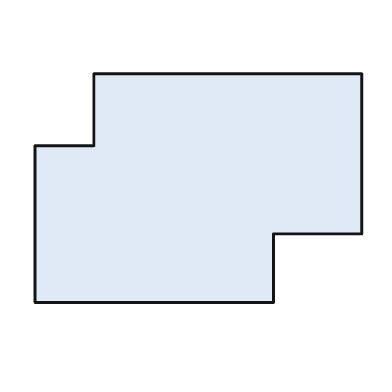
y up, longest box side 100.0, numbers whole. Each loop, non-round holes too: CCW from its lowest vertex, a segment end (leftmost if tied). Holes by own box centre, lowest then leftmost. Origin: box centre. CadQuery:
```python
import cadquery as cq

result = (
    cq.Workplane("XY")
    .moveTo(-50.0, -35.0)
    .lineTo(23.0, -35.0)
    .lineTo(23.0, -14.0)
    .lineTo(50.0, -14.0)
    .lineTo(50.0, 35.0)
    .lineTo(-32.0, 35.0)
    .lineTo(-32.0, 13.0)
    .lineTo(-50.0, 13.0)
    .close()
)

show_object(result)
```